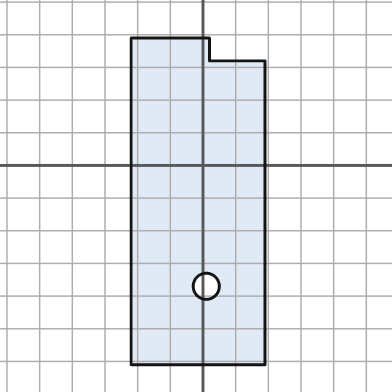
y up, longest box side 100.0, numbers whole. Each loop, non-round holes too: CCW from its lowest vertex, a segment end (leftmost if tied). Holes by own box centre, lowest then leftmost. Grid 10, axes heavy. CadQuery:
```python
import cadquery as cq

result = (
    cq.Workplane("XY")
    .moveTo(-22.0, -61.0)
    .lineTo(19.0, -61.0)
    .lineTo(19.0, 32.0)
    .lineTo(2.0, 32.0)
    .lineTo(2.0, 39.0)
    .lineTo(-22.0, 39.0)
    .close()
    .moveTo(1.0, -37.0)
    .circle(4.0)
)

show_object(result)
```